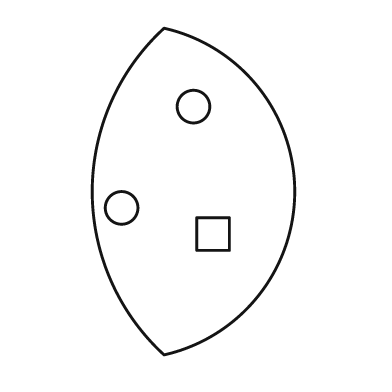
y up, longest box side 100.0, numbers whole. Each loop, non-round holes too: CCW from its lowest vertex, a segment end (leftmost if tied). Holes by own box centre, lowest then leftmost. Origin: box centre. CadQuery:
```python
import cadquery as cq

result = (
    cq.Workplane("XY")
    .moveTo(-9.0, -50.0)
    .threePointArc((31.0, 0.0), (-9.0, 50.0))
    .threePointArc((-31.0, 0.0), (-9.0, -50.0))
    .close()
    .moveTo(1.0, -18.0)
    .lineTo(11.0, -18.0)
    .lineTo(11.0, -8.0)
    .lineTo(1.0, -8.0)
    .close()
    .moveTo(-22.0, -5.0)
    .circle(5.0)
    .moveTo(0.0, 26.0)
    .circle(5.0)
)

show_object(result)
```